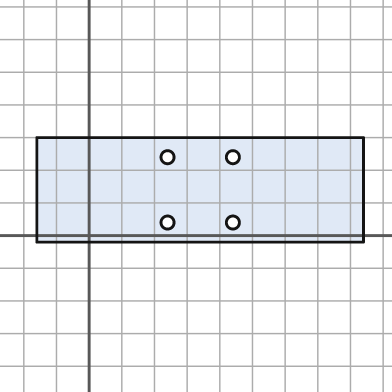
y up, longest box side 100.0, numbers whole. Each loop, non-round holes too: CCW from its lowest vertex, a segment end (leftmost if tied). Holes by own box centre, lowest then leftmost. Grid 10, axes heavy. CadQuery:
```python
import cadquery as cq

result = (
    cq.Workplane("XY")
    .moveTo(-16.0, -2.0)
    .lineTo(84.0, -2.0)
    .lineTo(84.0, 30.0)
    .lineTo(-16.0, 30.0)
    .close()
    .moveTo(24.0, 4.0)
    .circle(2.0)
    .moveTo(44.0, 4.0)
    .circle(2.0)
    .moveTo(24.0, 24.0)
    .circle(2.0)
    .moveTo(44.0, 24.0)
    .circle(2.0)
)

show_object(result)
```